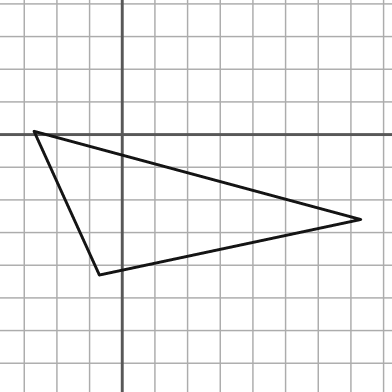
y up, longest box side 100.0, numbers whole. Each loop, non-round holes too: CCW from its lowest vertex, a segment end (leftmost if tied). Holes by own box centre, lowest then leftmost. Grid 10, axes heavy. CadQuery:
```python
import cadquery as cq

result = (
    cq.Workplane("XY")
    .moveTo(-7.0, -43.0)
    .lineTo(73.0, -26.0)
    .lineTo(-27.0, 1.0)
    .close()
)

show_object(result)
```